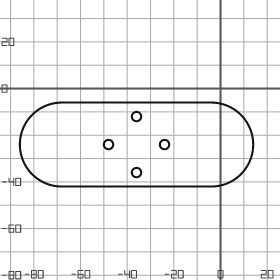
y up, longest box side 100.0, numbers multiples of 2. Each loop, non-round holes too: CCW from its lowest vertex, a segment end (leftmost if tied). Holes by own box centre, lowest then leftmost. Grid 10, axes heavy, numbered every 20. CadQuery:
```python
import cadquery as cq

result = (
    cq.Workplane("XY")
    .moveTo(-68.0, -42.0)
    .lineTo(-4.0, -42.0)
    .threePointArc((14.0, -24.0), (-4.0, -6.0))
    .lineTo(-68.0, -6.0)
    .threePointArc((-86.0, -24.0), (-68.0, -42.0))
    .close()
    .moveTo(-36.0, -36.0)
    .circle(2.0)
    .moveTo(-48.0, -24.0)
    .circle(2.0)
    .moveTo(-24.0, -24.0)
    .circle(2.0)
    .moveTo(-36.0, -12.0)
    .circle(2.0)
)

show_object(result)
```